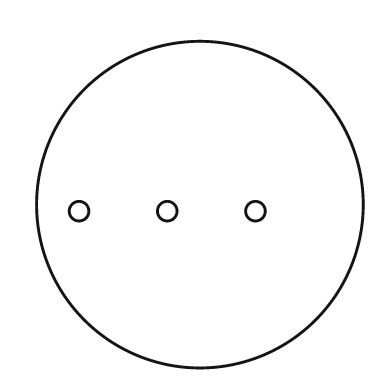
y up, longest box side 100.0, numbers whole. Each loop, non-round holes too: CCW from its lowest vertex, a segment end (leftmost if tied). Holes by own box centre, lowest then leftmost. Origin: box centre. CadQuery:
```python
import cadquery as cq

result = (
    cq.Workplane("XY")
    .moveTo(0.0, 0.0)
    .circle(50.0)
    .moveTo(-37.0, -2.0)
    .circle(3.0)
    .moveTo(-10.0, -2.0)
    .circle(3.0)
    .moveTo(17.0, -2.0)
    .circle(3.0)
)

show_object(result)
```